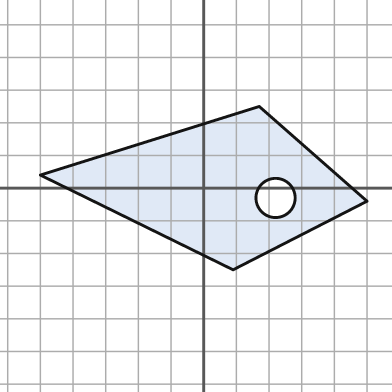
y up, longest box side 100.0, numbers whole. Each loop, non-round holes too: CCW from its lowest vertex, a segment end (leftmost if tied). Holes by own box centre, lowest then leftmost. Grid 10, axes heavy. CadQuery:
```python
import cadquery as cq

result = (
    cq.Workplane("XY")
    .moveTo(9.0, -25.0)
    .lineTo(50.0, -4.0)
    .lineTo(17.0, 25.0)
    .lineTo(-50.0, 4.0)
    .close()
    .moveTo(22.0, -3.0)
    .circle(6.0)
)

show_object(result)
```